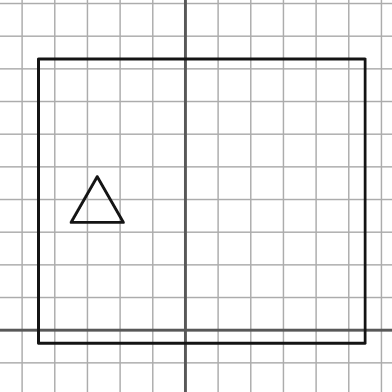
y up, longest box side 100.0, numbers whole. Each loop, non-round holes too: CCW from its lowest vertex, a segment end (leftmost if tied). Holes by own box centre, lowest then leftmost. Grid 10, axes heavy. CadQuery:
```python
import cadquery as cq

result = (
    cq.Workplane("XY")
    .moveTo(-45.0, -4.0)
    .lineTo(55.0, -4.0)
    .lineTo(55.0, 83.0)
    .lineTo(-45.0, 83.0)
    .close()
    .moveTo(-35.0, 33.0)
    .lineTo(-19.0, 33.0)
    .lineTo(-27.0, 47.0)
    .close()
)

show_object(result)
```